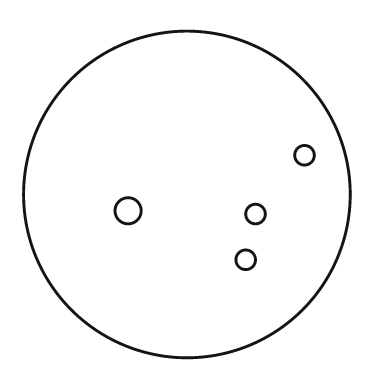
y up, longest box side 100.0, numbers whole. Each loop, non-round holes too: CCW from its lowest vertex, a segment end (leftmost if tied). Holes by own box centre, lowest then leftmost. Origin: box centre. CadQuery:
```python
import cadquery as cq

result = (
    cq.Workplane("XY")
    .moveTo(0.0, 0.0)
    .circle(50.0)
    .moveTo(18.0, -20.0)
    .circle(3.0)
    .moveTo(21.0, -6.0)
    .circle(3.0)
    .moveTo(-18.0, -5.0)
    .circle(4.0)
    .moveTo(36.0, 12.0)
    .circle(3.0)
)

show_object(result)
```